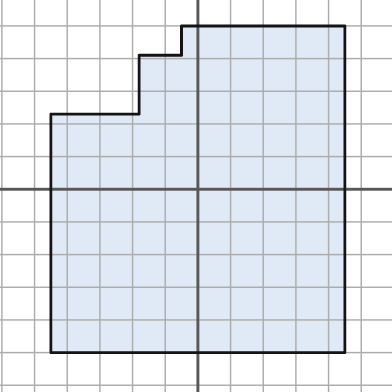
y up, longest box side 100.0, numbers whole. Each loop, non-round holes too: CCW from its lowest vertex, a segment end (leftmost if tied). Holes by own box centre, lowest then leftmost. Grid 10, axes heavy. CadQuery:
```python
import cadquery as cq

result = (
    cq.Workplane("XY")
    .moveTo(-45.0, -50.0)
    .lineTo(45.0, -50.0)
    .lineTo(45.0, 50.0)
    .lineTo(-5.0, 50.0)
    .lineTo(-5.0, 41.0)
    .lineTo(-18.0, 41.0)
    .lineTo(-18.0, 23.0)
    .lineTo(-45.0, 23.0)
    .close()
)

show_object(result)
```